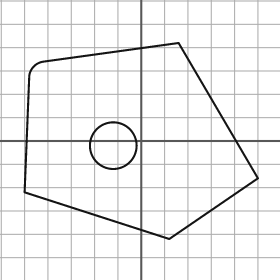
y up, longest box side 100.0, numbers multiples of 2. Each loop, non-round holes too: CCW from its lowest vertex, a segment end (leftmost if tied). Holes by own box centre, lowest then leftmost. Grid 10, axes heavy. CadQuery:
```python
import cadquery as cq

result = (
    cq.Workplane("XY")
    .moveTo(12.0, -42.0)
    .lineTo(50.0, -16.0)
    .lineTo(16.0, 42.0)
    .lineTo(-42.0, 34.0)
    .threePointArc((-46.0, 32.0), (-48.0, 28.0))
    .lineTo(-50.0, -22.0)
    .close()
    .moveTo(-12.0, -2.0)
    .circle(10.0)
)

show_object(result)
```